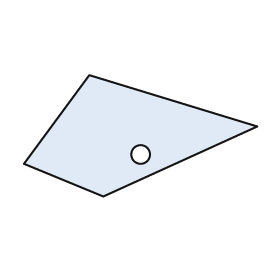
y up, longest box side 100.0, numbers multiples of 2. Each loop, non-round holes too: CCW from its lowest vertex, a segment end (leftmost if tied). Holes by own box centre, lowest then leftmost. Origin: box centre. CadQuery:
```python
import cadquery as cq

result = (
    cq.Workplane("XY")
    .moveTo(-16.0, -26.0)
    .lineTo(50.0, 4.0)
    .lineTo(-22.0, 26.0)
    .lineTo(-50.0, -12.0)
    .close()
    .moveTo(0.0, -8.0)
    .circle(4.0)
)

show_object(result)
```